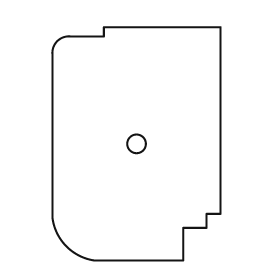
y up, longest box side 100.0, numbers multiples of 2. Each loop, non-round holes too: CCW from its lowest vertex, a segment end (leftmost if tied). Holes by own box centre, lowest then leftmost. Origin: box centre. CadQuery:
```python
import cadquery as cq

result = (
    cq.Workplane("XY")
    .moveTo(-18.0, -50.0)
    .lineTo(20.0, -50.0)
    .lineTo(20.0, -36.0)
    .lineTo(30.0, -36.0)
    .lineTo(30.0, -30.0)
    .lineTo(36.0, -30.0)
    .lineTo(36.0, 50.0)
    .lineTo(-14.0, 50.0)
    .lineTo(-14.0, 46.0)
    .lineTo(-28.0, 46.0)
    .threePointArc((-34.0, 44.0), (-36.0, 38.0))
    .lineTo(-36.0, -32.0)
    .threePointArc((-30.0, -44.0), (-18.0, -50.0))
    .close()
    .moveTo(0.0, 0.0)
    .circle(4.0)
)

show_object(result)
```